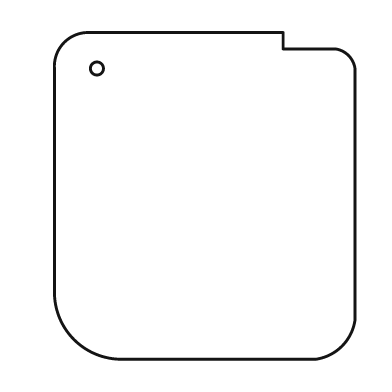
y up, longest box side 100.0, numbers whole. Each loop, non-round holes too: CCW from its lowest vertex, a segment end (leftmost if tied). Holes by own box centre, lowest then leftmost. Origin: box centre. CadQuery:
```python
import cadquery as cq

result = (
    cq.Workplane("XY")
    .moveTo(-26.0, -50.0)
    .lineTo(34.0, -50.0)
    .threePointArc((42.0, -46.0), (46.0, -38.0))
    .lineTo(46.0, 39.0)
    .threePointArc((44.0, 43.0), (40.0, 45.0))
    .lineTo(24.0, 45.0)
    .lineTo(24.0, 50.0)
    .lineTo(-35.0, 50.0)
    .threePointArc((-43.0, 47.0), (-46.0, 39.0))
    .lineTo(-46.0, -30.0)
    .threePointArc((-40.0, -44.0), (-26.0, -50.0))
    .close()
    .moveTo(-33.0, 39.0)
    .circle(2.0)
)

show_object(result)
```